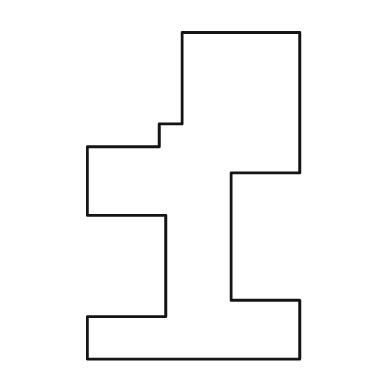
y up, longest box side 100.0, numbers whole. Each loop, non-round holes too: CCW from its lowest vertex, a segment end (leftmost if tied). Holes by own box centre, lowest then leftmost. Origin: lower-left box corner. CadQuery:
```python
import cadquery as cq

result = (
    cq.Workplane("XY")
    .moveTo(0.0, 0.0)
    .lineTo(65.0, 0.0)
    .lineTo(65.0, 18.0)
    .lineTo(44.0, 18.0)
    .lineTo(44.0, 57.0)
    .lineTo(65.0, 57.0)
    .lineTo(65.0, 100.0)
    .lineTo(29.0, 100.0)
    .lineTo(29.0, 72.0)
    .lineTo(22.0, 72.0)
    .lineTo(22.0, 65.0)
    .lineTo(0.0, 65.0)
    .lineTo(0.0, 44.0)
    .lineTo(24.0, 44.0)
    .lineTo(24.0, 13.0)
    .lineTo(0.0, 13.0)
    .close()
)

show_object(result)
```